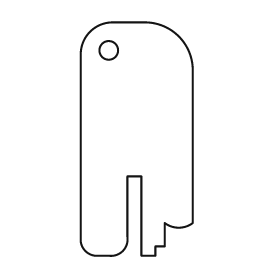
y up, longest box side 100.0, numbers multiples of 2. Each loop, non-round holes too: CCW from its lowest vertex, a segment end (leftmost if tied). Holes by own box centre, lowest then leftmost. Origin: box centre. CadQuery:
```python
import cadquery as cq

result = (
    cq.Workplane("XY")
    .moveTo(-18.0, -50.0)
    .lineTo(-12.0, -50.0)
    .threePointArc((-6.0, -48.0), (-4.0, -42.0))
    .lineTo(-4.0, -16.0)
    .lineTo(2.0, -16.0)
    .lineTo(2.0, -50.0)
    .lineTo(8.0, -50.0)
    .lineTo(8.0, -46.0)
    .lineTo(12.0, -46.0)
    .lineTo(12.0, -36.0)
    .threePointArc((18.0, -38.0), (24.0, -36.0))
    .lineTo(24.0, 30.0)
    .threePointArc((18.0, 44.0), (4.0, 50.0))
    .lineTo(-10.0, 50.0)
    .threePointArc((-20.0, 46.0), (-24.0, 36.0))
    .lineTo(-24.0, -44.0)
    .threePointArc((-22.0, -48.0), (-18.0, -50.0))
    .close()
    .moveTo(-12.0, 38.0)
    .circle(4.0)
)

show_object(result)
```